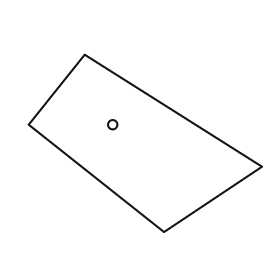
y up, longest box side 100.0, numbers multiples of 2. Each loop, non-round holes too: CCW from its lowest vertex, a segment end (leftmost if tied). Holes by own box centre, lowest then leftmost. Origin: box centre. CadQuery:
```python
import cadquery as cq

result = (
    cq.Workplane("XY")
    .moveTo(8.0, -38.0)
    .lineTo(50.0, -10.0)
    .lineTo(-26.0, 38.0)
    .lineTo(-50.0, 8.0)
    .close()
    .moveTo(-14.0, 8.0)
    .circle(2.0)
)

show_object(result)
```